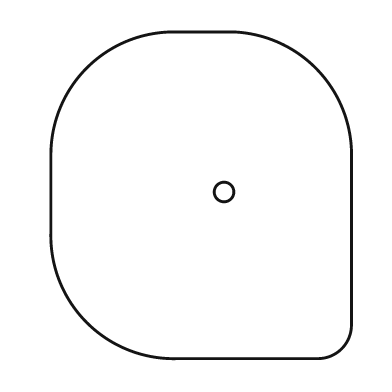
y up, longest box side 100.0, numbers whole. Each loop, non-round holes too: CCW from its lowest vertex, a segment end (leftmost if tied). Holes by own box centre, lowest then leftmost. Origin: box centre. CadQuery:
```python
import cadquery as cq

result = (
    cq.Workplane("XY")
    .moveTo(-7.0, -50.0)
    .lineTo(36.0, -50.0)
    .threePointArc((43.0, -47.0), (46.0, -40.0))
    .lineTo(46.0, 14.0)
    .threePointArc((35.0, 39.0), (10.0, 50.0))
    .lineTo(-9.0, 50.0)
    .threePointArc((-35.0, 39.0), (-46.0, 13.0))
    .lineTo(-46.0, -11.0)
    .threePointArc((-35.0, -39.0), (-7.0, -50.0))
    .close()
    .moveTo(7.0, 1.0)
    .circle(3.0)
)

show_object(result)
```